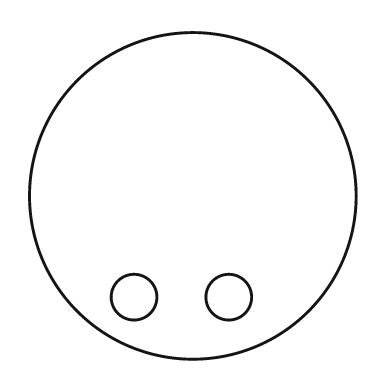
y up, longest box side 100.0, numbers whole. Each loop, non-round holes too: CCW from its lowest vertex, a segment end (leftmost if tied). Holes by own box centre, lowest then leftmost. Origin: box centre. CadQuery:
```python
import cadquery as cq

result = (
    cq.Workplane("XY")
    .moveTo(0.0, 0.0)
    .circle(50.0)
    .moveTo(-18.0, -31.0)
    .circle(7.0)
    .moveTo(11.0, -31.0)
    .circle(7.0)
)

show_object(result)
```